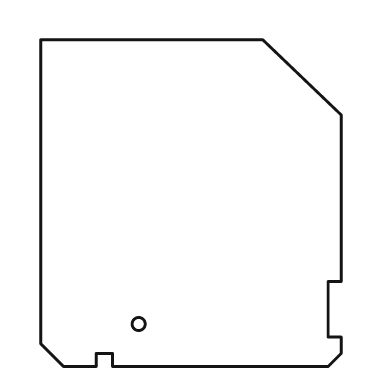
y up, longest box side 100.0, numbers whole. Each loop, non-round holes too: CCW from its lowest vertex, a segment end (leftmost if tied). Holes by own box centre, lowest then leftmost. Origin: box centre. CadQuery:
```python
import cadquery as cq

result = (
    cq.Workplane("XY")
    .moveTo(-39.0, -50.0)
    .lineTo(-29.0, -50.0)
    .lineTo(-29.0, -46.0)
    .lineTo(-24.0, -46.0)
    .lineTo(-24.0, -50.0)
    .lineTo(42.0, -50.0)
    .lineTo(46.0, -46.0)
    .lineTo(46.0, -41.0)
    .lineTo(42.0, -41.0)
    .lineTo(42.0, -24.0)
    .lineTo(46.0, -24.0)
    .lineTo(46.0, 27.0)
    .lineTo(22.0, 50.0)
    .lineTo(-46.0, 50.0)
    .lineTo(-46.0, -43.0)
    .close()
    .moveTo(-16.0, -37.0)
    .circle(2.0)
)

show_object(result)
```